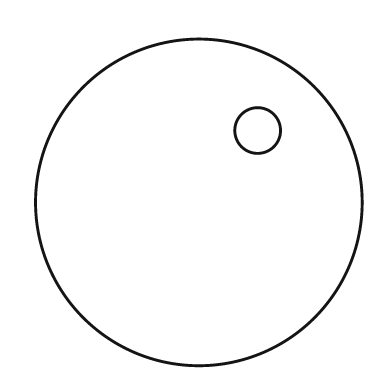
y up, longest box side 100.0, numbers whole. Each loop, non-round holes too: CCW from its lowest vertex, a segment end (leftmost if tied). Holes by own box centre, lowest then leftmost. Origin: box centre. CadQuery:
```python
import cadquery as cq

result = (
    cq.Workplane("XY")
    .moveTo(0.0, 0.0)
    .circle(50.0)
    .moveTo(18.0, 22.0)
    .circle(7.0)
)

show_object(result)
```